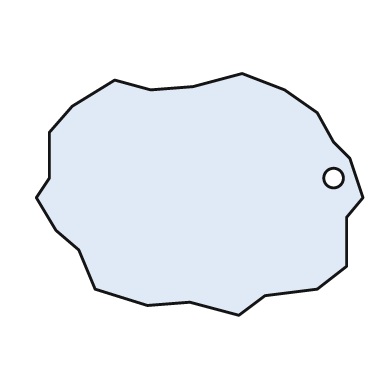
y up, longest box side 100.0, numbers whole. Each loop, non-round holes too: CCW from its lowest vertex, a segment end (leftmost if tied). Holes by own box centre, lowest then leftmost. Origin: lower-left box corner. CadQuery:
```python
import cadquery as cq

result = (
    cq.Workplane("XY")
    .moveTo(62.0, 0.0)
    .lineTo(70.0, 6.0)
    .lineTo(86.0, 8.0)
    .lineTo(95.0, 15.0)
    .lineTo(95.0, 30.0)
    .lineTo(100.0, 36.0)
    .lineTo(96.0, 48.0)
    .lineTo(91.0, 53.0)
    .lineTo(86.0, 62.0)
    .lineTo(76.0, 69.0)
    .lineTo(63.0, 74.0)
    .lineTo(48.0, 70.0)
    .lineTo(35.0, 69.0)
    .lineTo(24.0, 72.0)
    .lineTo(11.0, 64.0)
    .lineTo(4.0, 56.0)
    .lineTo(4.0, 42.0)
    .lineTo(0.0, 36.0)
    .lineTo(6.0, 26.0)
    .lineTo(13.0, 20.0)
    .lineTo(18.0, 8.0)
    .lineTo(34.0, 3.0)
    .lineTo(47.0, 4.0)
    .close()
    .moveTo(91.0, 42.0)
    .circle(3.0)
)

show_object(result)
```